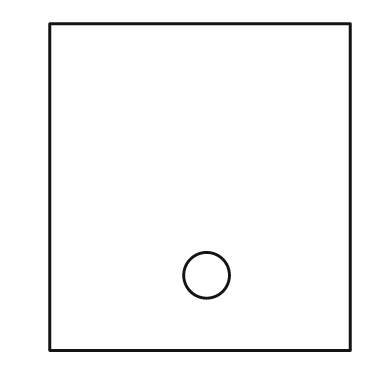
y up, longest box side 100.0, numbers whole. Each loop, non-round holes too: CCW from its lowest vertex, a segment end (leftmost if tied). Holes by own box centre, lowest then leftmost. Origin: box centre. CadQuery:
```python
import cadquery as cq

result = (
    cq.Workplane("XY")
    .moveTo(-46.0, -50.0)
    .lineTo(46.0, -50.0)
    .lineTo(46.0, 50.0)
    .lineTo(-46.0, 50.0)
    .close()
    .moveTo(2.0, -27.0)
    .circle(7.0)
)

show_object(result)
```